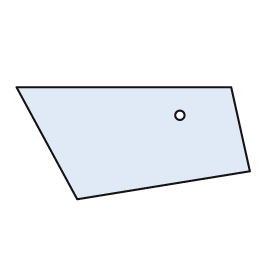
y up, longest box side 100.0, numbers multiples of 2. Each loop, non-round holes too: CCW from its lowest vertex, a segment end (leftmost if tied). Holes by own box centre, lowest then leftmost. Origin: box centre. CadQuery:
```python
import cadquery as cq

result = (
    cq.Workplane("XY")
    .moveTo(-24.0, -24.0)
    .lineTo(50.0, -12.0)
    .lineTo(42.0, 24.0)
    .lineTo(-50.0, 24.0)
    .close()
    .moveTo(20.0, 12.0)
    .circle(2.0)
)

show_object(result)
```